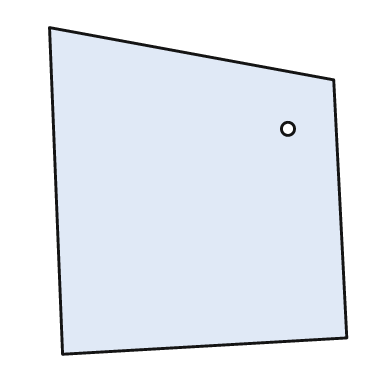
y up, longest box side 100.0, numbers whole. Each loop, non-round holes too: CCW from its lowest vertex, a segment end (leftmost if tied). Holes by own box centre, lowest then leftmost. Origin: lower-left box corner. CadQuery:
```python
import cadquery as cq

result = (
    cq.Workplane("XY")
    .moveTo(4.0, 0.0)
    .lineTo(91.0, 5.0)
    .lineTo(87.0, 84.0)
    .lineTo(0.0, 100.0)
    .close()
    .moveTo(73.0, 69.0)
    .circle(2.0)
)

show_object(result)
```